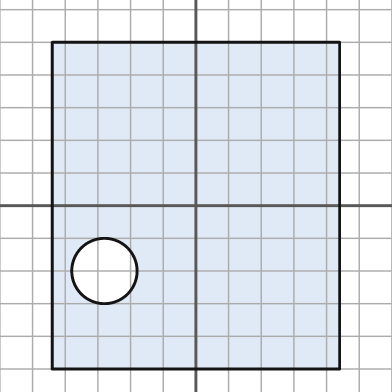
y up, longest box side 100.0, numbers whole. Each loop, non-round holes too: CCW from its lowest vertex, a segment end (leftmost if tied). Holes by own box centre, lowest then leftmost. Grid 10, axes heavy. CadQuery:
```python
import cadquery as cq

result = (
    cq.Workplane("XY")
    .moveTo(-44.0, -50.0)
    .lineTo(44.0, -50.0)
    .lineTo(44.0, 50.0)
    .lineTo(-44.0, 50.0)
    .close()
    .moveTo(-28.0, -20.0)
    .circle(10.0)
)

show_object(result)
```